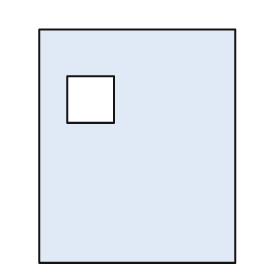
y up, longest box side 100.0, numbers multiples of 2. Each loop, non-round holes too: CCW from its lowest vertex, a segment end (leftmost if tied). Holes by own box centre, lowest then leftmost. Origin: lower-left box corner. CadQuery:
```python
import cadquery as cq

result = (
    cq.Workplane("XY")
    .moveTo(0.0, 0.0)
    .lineTo(84.0, 0.0)
    .lineTo(84.0, 100.0)
    .lineTo(0.0, 100.0)
    .close()
    .moveTo(12.0, 60.0)
    .lineTo(32.0, 60.0)
    .lineTo(32.0, 80.0)
    .lineTo(12.0, 80.0)
    .close()
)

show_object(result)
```